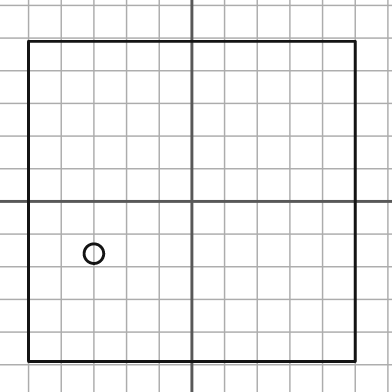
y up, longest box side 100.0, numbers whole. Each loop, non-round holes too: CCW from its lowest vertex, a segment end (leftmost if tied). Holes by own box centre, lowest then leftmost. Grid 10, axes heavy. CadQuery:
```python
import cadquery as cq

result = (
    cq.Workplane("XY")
    .moveTo(-50.0, -49.0)
    .lineTo(50.0, -49.0)
    .lineTo(50.0, 49.0)
    .lineTo(-50.0, 49.0)
    .close()
    .moveTo(-30.0, -16.0)
    .circle(3.0)
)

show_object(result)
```